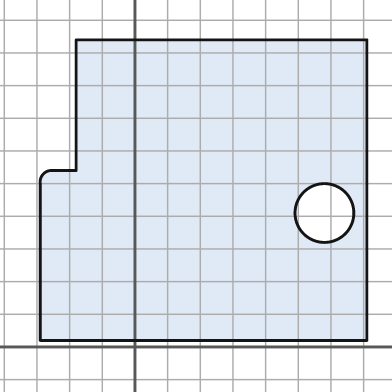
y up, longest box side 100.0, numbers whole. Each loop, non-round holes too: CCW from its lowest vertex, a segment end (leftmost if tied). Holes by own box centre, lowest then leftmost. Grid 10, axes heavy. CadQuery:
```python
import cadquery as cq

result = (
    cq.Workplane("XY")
    .moveTo(-29.0, 2.0)
    .lineTo(71.0, 2.0)
    .lineTo(71.0, 94.0)
    .lineTo(-18.0, 94.0)
    .lineTo(-18.0, 54.0)
    .lineTo(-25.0, 54.0)
    .threePointArc((-28.0, 53.0), (-29.0, 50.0))
    .close()
    .moveTo(58.0, 41.0)
    .circle(9.0)
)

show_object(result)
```